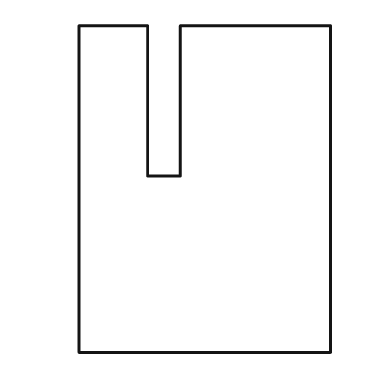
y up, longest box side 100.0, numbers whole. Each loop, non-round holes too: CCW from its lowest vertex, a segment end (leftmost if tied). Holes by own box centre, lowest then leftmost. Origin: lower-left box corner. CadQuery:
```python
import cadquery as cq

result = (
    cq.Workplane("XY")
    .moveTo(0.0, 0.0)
    .lineTo(77.0, 0.0)
    .lineTo(77.0, 100.0)
    .lineTo(31.0, 100.0)
    .lineTo(31.0, 54.0)
    .lineTo(21.0, 54.0)
    .lineTo(21.0, 100.0)
    .lineTo(0.0, 100.0)
    .close()
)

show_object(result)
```